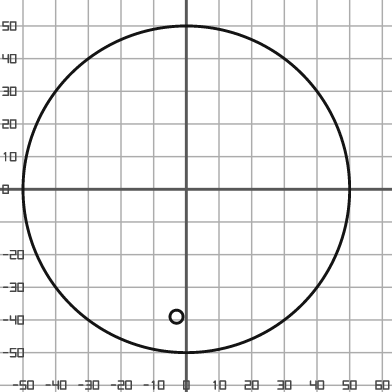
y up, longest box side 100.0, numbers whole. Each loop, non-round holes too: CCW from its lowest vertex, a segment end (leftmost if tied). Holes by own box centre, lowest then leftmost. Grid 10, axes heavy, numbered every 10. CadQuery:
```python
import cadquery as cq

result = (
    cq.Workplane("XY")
    .moveTo(0.0, 0.0)
    .circle(50.0)
    .moveTo(-3.0, -39.0)
    .circle(2.0)
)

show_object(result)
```